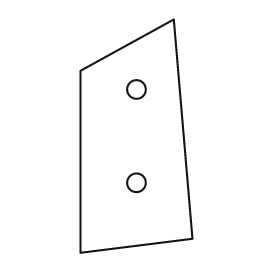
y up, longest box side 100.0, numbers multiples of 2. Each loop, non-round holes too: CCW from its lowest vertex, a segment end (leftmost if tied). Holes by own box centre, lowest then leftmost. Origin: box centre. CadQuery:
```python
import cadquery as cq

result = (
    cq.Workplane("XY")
    .moveTo(-24.0, -50.0)
    .lineTo(24.0, -44.0)
    .lineTo(16.0, 50.0)
    .lineTo(-24.0, 28.0)
    .close()
    .moveTo(0.0, -20.0)
    .circle(4.0)
    .moveTo(0.0, 20.0)
    .circle(4.0)
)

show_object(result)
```